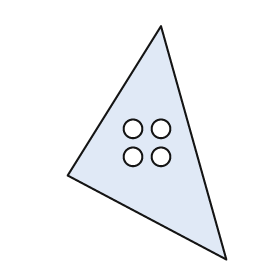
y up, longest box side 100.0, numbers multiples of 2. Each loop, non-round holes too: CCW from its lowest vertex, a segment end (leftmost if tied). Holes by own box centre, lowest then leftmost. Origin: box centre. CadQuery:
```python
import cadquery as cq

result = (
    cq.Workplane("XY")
    .moveTo(34.0, -50.0)
    .lineTo(6.0, 50.0)
    .lineTo(-34.0, -14.0)
    .close()
    .moveTo(-6.0, -6.0)
    .circle(4.0)
    .moveTo(6.0, -6.0)
    .circle(4.0)
    .moveTo(-6.0, 6.0)
    .circle(4.0)
    .moveTo(6.0, 6.0)
    .circle(4.0)
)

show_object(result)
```